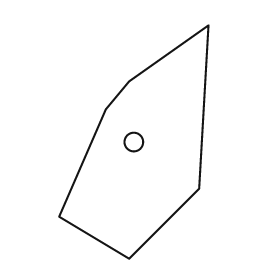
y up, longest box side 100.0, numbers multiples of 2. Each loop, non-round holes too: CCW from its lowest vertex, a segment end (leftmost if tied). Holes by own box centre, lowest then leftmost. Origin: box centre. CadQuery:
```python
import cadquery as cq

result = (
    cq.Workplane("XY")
    .moveTo(-2.0, -50.0)
    .lineTo(28.0, -20.0)
    .lineTo(32.0, 50.0)
    .lineTo(-2.0, 26.0)
    .lineTo(-12.0, 14.0)
    .lineTo(-32.0, -32.0)
    .close()
    .moveTo(0.0, 0.0)
    .circle(4.0)
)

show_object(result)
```